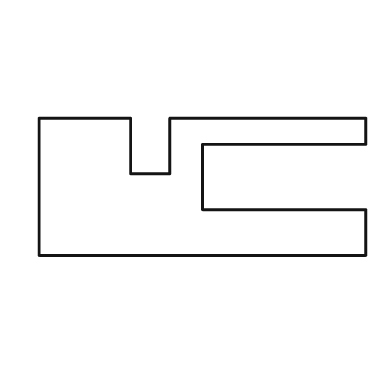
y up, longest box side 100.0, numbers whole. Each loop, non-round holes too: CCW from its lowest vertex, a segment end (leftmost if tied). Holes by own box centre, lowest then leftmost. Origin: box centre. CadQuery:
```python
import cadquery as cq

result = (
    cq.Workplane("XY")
    .moveTo(-50.0, -21.0)
    .lineTo(50.0, -21.0)
    .lineTo(50.0, -7.0)
    .lineTo(0.0, -7.0)
    .lineTo(0.0, 13.0)
    .lineTo(50.0, 13.0)
    .lineTo(50.0, 21.0)
    .lineTo(-10.0, 21.0)
    .lineTo(-10.0, 4.0)
    .lineTo(-22.0, 4.0)
    .lineTo(-22.0, 21.0)
    .lineTo(-50.0, 21.0)
    .close()
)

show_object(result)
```